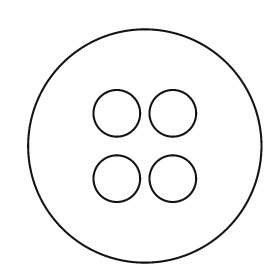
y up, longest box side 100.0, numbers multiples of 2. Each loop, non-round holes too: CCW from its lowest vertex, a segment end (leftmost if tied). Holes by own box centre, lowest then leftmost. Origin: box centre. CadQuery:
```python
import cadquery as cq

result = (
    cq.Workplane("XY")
    .moveTo(0.0, 0.0)
    .circle(50.0)
    .moveTo(-12.0, -14.0)
    .circle(10.0)
    .moveTo(12.0, -14.0)
    .circle(10.0)
    .moveTo(-12.0, 14.0)
    .circle(10.0)
    .moveTo(12.0, 14.0)
    .circle(10.0)
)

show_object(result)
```